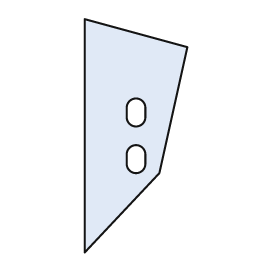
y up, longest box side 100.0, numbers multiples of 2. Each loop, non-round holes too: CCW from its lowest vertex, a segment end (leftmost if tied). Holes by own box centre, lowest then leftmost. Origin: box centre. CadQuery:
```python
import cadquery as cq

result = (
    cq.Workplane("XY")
    .moveTo(-22.0, -50.0)
    .lineTo(10.0, -16.0)
    .lineTo(22.0, 38.0)
    .lineTo(-22.0, 50.0)
    .close()
    .moveTo(-4.0, -12.0)
    .threePointArc((0.0, -16.0), (4.0, -12.0))
    .lineTo(4.0, -8.0)
    .threePointArc((0.0, -4.0), (-4.0, -8.0))
    .close()
    .moveTo(-4.0, 8.0)
    .threePointArc((0.0, 4.0), (4.0, 8.0))
    .lineTo(4.0, 12.0)
    .threePointArc((0.0, 16.0), (-4.0, 12.0))
    .close()
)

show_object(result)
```